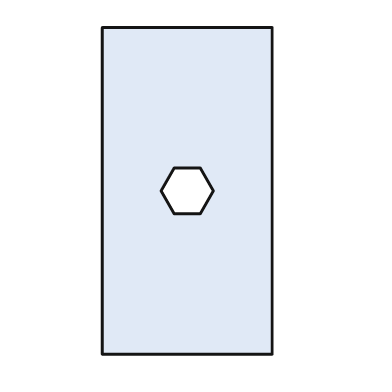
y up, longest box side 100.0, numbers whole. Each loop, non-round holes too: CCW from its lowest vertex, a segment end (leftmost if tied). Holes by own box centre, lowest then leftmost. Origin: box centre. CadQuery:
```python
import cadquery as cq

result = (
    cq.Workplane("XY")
    .moveTo(-26.0, -50.0)
    .lineTo(26.0, -50.0)
    .lineTo(26.0, 50.0)
    .lineTo(-26.0, 50.0)
    .close()
    .moveTo(-4.0, -7.0)
    .lineTo(4.0, -7.0)
    .lineTo(8.0, 0.0)
    .lineTo(4.0, 7.0)
    .lineTo(-4.0, 7.0)
    .lineTo(-8.0, 0.0)
    .close()
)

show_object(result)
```